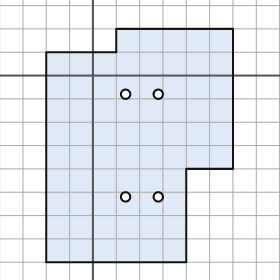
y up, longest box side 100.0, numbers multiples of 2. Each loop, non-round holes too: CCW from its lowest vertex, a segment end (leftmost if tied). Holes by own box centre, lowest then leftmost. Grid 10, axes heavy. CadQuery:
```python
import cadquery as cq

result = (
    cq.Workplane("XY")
    .moveTo(-20.0, -80.0)
    .lineTo(40.0, -80.0)
    .lineTo(40.0, -40.0)
    .lineTo(60.0, -40.0)
    .lineTo(60.0, 20.0)
    .lineTo(10.0, 20.0)
    .lineTo(10.0, 10.0)
    .lineTo(-20.0, 10.0)
    .close()
    .moveTo(14.0, -52.0)
    .circle(2.0)
    .moveTo(28.0, -52.0)
    .circle(2.0)
    .moveTo(14.0, -8.0)
    .circle(2.0)
    .moveTo(28.0, -8.0)
    .circle(2.0)
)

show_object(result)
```